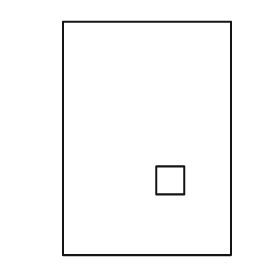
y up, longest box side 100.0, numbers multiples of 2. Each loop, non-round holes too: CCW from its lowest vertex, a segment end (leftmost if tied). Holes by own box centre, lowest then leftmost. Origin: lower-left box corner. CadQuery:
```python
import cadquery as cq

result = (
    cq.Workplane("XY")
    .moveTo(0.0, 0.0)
    .lineTo(72.0, 0.0)
    .lineTo(72.0, 100.0)
    .lineTo(0.0, 100.0)
    .close()
    .moveTo(40.0, 26.0)
    .lineTo(52.0, 26.0)
    .lineTo(52.0, 38.0)
    .lineTo(40.0, 38.0)
    .close()
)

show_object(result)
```